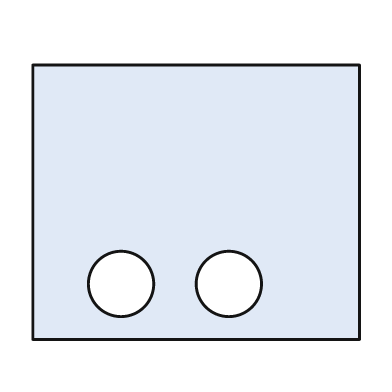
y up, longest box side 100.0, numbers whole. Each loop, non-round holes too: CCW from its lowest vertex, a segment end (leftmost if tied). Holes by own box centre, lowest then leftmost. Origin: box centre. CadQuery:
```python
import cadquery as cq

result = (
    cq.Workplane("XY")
    .moveTo(-50.0, -42.0)
    .lineTo(50.0, -42.0)
    .lineTo(50.0, 42.0)
    .lineTo(-50.0, 42.0)
    .close()
    .moveTo(-23.0, -25.0)
    .circle(10.0)
    .moveTo(10.0, -25.0)
    .circle(10.0)
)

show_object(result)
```